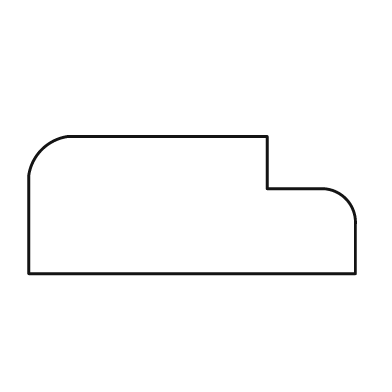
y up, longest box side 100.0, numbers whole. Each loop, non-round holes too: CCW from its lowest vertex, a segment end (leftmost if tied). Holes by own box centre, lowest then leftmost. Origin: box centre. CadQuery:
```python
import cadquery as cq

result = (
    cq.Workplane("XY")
    .moveTo(-50.0, -21.0)
    .lineTo(50.0, -21.0)
    .lineTo(50.0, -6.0)
    .threePointArc((47.0, 2.0), (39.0, 5.0))
    .lineTo(23.0, 5.0)
    .lineTo(23.0, 21.0)
    .lineTo(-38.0, 21.0)
    .threePointArc((-46.0, 17.0), (-50.0, 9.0))
    .close()
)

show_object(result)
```